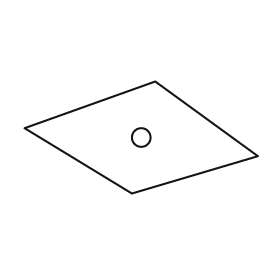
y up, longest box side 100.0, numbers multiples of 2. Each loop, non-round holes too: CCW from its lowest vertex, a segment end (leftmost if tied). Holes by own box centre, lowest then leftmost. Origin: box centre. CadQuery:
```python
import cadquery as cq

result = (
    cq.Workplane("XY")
    .moveTo(-4.0, -24.0)
    .lineTo(50.0, -8.0)
    .lineTo(6.0, 24.0)
    .lineTo(-50.0, 4.0)
    .close()
    .moveTo(0.0, 0.0)
    .circle(4.0)
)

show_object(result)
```